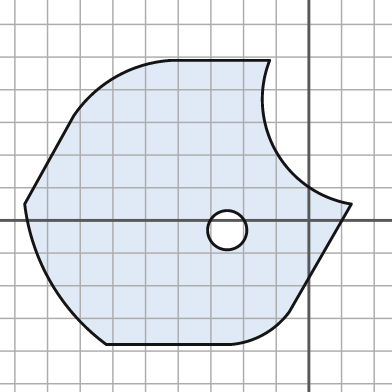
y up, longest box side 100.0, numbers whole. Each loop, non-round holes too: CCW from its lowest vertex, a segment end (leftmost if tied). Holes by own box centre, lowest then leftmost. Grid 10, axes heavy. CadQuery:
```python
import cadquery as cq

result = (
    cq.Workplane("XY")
    .moveTo(-62.0, -38.0)
    .lineTo(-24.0, -38.0)
    .threePointArc((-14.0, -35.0), (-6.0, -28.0))
    .lineTo(13.0, 5.0)
    .threePointArc((-10.0, 21.0), (-12.0, 49.0))
    .lineTo(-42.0, 49.0)
    .threePointArc((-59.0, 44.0), (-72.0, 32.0))
    .lineTo(-87.0, 5.0)
    .threePointArc((-79.0, -19.0), (-62.0, -38.0))
    .close()
    .moveTo(-25.0, -3.0)
    .circle(6.0)
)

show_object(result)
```